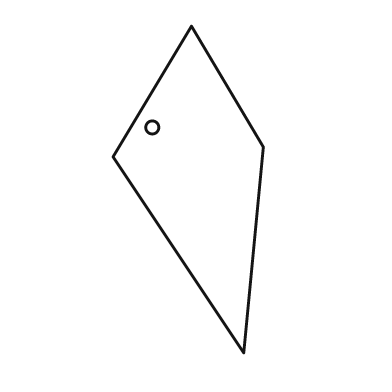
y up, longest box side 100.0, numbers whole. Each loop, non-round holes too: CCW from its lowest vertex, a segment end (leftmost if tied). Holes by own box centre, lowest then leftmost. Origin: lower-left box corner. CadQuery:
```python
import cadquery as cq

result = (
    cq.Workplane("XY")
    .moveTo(40.0, 0.0)
    .lineTo(46.0, 63.0)
    .lineTo(24.0, 100.0)
    .lineTo(0.0, 60.0)
    .close()
    .moveTo(12.0, 69.0)
    .circle(2.0)
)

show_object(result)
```